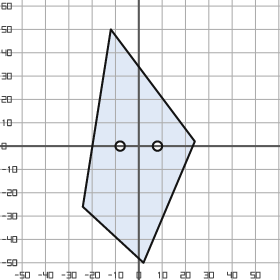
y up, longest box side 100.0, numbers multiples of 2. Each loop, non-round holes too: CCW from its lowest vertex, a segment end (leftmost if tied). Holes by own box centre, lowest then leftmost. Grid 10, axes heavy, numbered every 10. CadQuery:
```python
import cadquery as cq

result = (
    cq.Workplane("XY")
    .moveTo(2.0, -50.0)
    .lineTo(24.0, 2.0)
    .lineTo(-12.0, 50.0)
    .lineTo(-24.0, -26.0)
    .close()
    .moveTo(-8.0, 0.0)
    .circle(2.0)
    .moveTo(8.0, 0.0)
    .circle(2.0)
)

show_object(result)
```